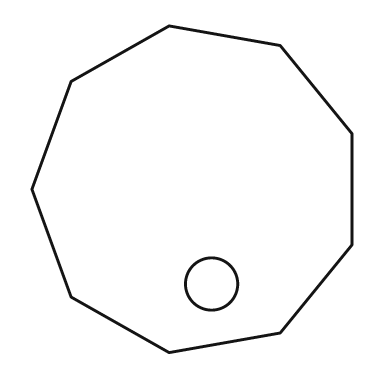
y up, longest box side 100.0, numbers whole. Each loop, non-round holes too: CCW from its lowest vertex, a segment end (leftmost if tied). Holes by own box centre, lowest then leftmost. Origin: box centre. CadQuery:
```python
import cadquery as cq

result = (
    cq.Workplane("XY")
    .moveTo(-7.0, -50.0)
    .lineTo(27.0, -44.0)
    .lineTo(49.0, -17.0)
    .lineTo(49.0, 17.0)
    .lineTo(27.0, 44.0)
    .lineTo(-7.0, 50.0)
    .lineTo(-37.0, 33.0)
    .lineTo(-49.0, 0.0)
    .lineTo(-37.0, -33.0)
    .close()
    .moveTo(6.0, -29.0)
    .circle(8.0)
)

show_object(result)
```